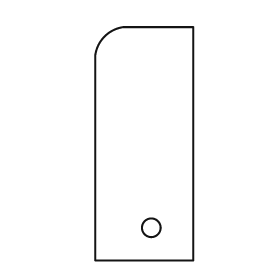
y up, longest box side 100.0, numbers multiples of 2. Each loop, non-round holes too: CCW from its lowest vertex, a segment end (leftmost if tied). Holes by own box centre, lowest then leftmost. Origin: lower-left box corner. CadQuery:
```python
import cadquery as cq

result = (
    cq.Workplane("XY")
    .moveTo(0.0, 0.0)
    .lineTo(42.0, 0.0)
    .lineTo(42.0, 100.0)
    .lineTo(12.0, 100.0)
    .threePointArc((4.0, 96.0), (0.0, 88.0))
    .close()
    .moveTo(24.0, 14.0)
    .circle(4.0)
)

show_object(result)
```